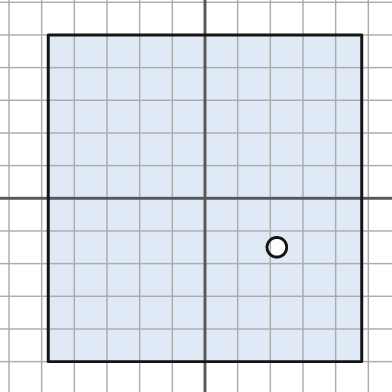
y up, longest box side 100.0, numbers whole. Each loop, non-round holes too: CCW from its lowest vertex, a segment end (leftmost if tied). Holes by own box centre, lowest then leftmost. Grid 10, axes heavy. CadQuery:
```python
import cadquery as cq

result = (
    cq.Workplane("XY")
    .moveTo(-48.0, -50.0)
    .lineTo(48.0, -50.0)
    .lineTo(48.0, 50.0)
    .lineTo(-48.0, 50.0)
    .close()
    .moveTo(22.0, -15.0)
    .circle(3.0)
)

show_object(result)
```